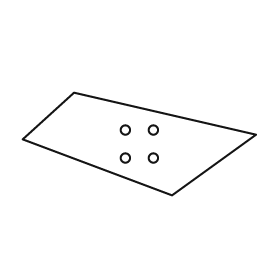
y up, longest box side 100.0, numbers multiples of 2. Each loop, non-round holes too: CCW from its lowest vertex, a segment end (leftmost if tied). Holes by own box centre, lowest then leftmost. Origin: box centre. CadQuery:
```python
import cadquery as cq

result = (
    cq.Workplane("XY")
    .moveTo(14.0, -22.0)
    .lineTo(50.0, 4.0)
    .lineTo(-28.0, 22.0)
    .lineTo(-50.0, 2.0)
    .close()
    .moveTo(-6.0, -6.0)
    .circle(2.0)
    .moveTo(6.0, -6.0)
    .circle(2.0)
    .moveTo(-6.0, 6.0)
    .circle(2.0)
    .moveTo(6.0, 6.0)
    .circle(2.0)
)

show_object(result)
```